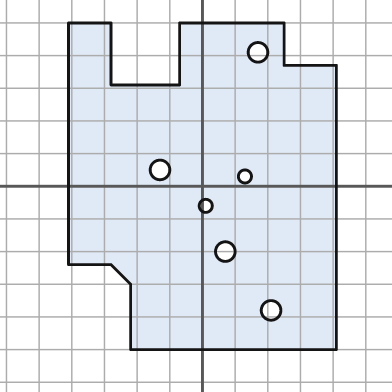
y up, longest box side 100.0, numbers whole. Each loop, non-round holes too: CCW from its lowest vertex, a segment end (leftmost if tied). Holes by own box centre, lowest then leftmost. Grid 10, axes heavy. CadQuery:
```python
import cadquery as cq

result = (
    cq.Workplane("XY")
    .moveTo(-22.0, -50.0)
    .lineTo(41.0, -50.0)
    .lineTo(41.0, 37.0)
    .lineTo(25.0, 37.0)
    .lineTo(25.0, 50.0)
    .lineTo(-7.0, 50.0)
    .lineTo(-7.0, 31.0)
    .lineTo(-28.0, 31.0)
    .lineTo(-28.0, 50.0)
    .lineTo(-41.0, 50.0)
    .lineTo(-41.0, -24.0)
    .lineTo(-28.0, -24.0)
    .lineTo(-22.0, -30.0)
    .close()
    .moveTo(21.0, -38.0)
    .circle(3.0)
    .moveTo(7.0, -20.0)
    .circle(3.0)
    .moveTo(1.0, -6.0)
    .circle(2.0)
    .moveTo(13.0, 3.0)
    .circle(2.0)
    .moveTo(-13.0, 5.0)
    .circle(3.0)
    .moveTo(17.0, 41.0)
    .circle(3.0)
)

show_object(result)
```